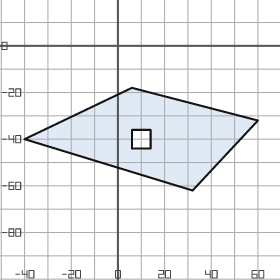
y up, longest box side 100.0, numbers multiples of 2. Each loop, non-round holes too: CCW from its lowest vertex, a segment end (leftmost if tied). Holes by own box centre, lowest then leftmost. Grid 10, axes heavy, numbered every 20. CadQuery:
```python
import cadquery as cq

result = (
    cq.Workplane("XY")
    .moveTo(32.0, -62.0)
    .lineTo(60.0, -32.0)
    .lineTo(6.0, -18.0)
    .lineTo(-40.0, -40.0)
    .close()
    .moveTo(6.0, -44.0)
    .lineTo(14.0, -44.0)
    .lineTo(14.0, -36.0)
    .lineTo(6.0, -36.0)
    .close()
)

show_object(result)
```